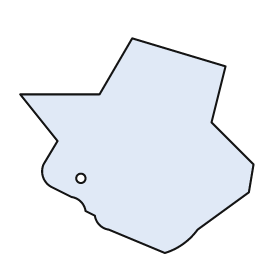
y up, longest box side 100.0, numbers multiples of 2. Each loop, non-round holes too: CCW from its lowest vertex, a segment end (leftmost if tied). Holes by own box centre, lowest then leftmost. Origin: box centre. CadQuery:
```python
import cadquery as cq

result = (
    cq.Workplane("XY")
    .moveTo(12.0, -46.0)
    .threePointArc((20.0, -42.0), (26.0, -36.0))
    .lineTo(48.0, -20.0)
    .lineTo(50.0, -8.0)
    .lineTo(32.0, 10.0)
    .lineTo(38.0, 34.0)
    .lineTo(-2.0, 46.0)
    .lineTo(-16.0, 22.0)
    .lineTo(-50.0, 22.0)
    .lineTo(-34.0, 2.0)
    .lineTo(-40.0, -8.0)
    .threePointArc((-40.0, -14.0), (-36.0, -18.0))
    .lineTo(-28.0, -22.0)
    .threePointArc((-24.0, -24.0), (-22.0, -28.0))
    .lineTo(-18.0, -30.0)
    .threePointArc((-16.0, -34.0), (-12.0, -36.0))
    .close()
    .moveTo(-24.0, -14.0)
    .circle(2.0)
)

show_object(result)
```